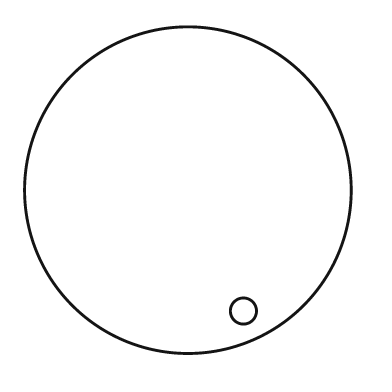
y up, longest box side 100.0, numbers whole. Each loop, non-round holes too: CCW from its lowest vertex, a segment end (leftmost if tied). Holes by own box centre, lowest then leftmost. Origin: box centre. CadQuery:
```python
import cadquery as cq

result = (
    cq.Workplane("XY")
    .moveTo(0.0, 0.0)
    .circle(50.0)
    .moveTo(17.0, -37.0)
    .circle(4.0)
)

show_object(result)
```